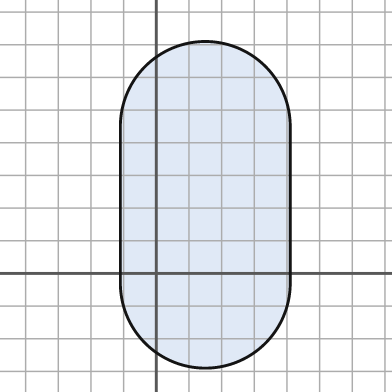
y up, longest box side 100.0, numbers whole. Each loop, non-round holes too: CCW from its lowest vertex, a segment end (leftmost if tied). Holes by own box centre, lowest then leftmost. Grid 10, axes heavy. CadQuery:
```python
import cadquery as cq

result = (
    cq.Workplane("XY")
    .moveTo(-11.0, -3.0)
    .threePointArc((15.0, -29.0), (41.0, -3.0))
    .lineTo(41.0, 45.0)
    .threePointArc((15.0, 71.0), (-11.0, 45.0))
    .close()
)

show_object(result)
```